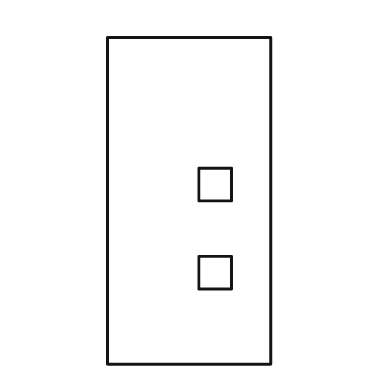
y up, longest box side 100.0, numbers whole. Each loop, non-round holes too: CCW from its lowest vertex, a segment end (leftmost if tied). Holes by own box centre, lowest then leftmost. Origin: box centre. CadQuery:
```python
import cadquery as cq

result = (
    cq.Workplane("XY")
    .moveTo(-25.0, -50.0)
    .lineTo(25.0, -50.0)
    .lineTo(25.0, 50.0)
    .lineTo(-25.0, 50.0)
    .close()
    .moveTo(3.0, -27.0)
    .lineTo(13.0, -27.0)
    .lineTo(13.0, -17.0)
    .lineTo(3.0, -17.0)
    .close()
    .moveTo(3.0, 0.0)
    .lineTo(13.0, 0.0)
    .lineTo(13.0, 10.0)
    .lineTo(3.0, 10.0)
    .close()
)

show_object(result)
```